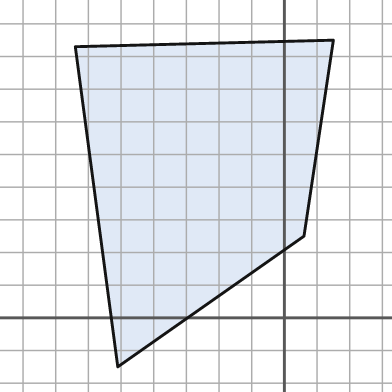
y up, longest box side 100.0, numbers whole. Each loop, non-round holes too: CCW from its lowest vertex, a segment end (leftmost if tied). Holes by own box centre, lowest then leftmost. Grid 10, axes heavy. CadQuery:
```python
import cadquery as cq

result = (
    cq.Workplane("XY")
    .moveTo(-51.0, -15.0)
    .lineTo(6.0, 25.0)
    .lineTo(15.0, 85.0)
    .lineTo(-64.0, 83.0)
    .close()
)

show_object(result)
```